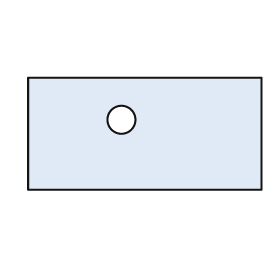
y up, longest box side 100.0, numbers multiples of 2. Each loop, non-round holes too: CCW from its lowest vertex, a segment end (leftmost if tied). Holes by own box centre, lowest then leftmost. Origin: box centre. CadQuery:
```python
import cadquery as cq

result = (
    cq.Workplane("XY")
    .moveTo(-50.0, -24.0)
    .lineTo(50.0, -24.0)
    .lineTo(50.0, 24.0)
    .lineTo(-50.0, 24.0)
    .close()
    .moveTo(-10.0, 6.0)
    .circle(6.0)
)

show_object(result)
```